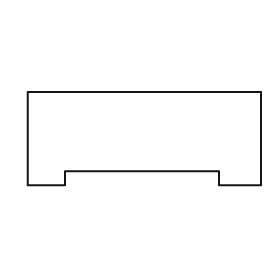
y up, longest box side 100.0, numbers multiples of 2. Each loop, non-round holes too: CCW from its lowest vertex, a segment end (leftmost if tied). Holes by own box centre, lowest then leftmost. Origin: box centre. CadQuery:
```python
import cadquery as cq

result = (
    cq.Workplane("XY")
    .moveTo(-50.0, -20.0)
    .lineTo(-34.0, -20.0)
    .lineTo(-34.0, -14.0)
    .lineTo(32.0, -14.0)
    .lineTo(32.0, -20.0)
    .lineTo(50.0, -20.0)
    .lineTo(50.0, 20.0)
    .lineTo(-50.0, 20.0)
    .close()
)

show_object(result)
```